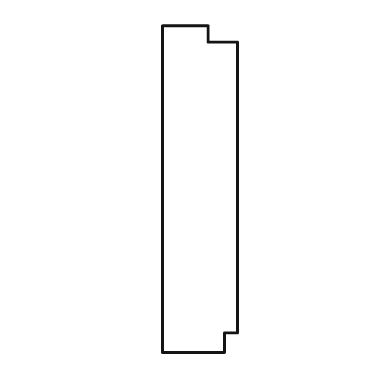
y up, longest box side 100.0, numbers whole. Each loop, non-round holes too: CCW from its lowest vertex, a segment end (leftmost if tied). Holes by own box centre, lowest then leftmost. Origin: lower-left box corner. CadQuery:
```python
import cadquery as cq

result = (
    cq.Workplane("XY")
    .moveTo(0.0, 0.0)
    .lineTo(19.0, 0.0)
    .lineTo(19.0, 6.0)
    .lineTo(23.0, 6.0)
    .lineTo(23.0, 95.0)
    .lineTo(14.0, 95.0)
    .lineTo(14.0, 100.0)
    .lineTo(0.0, 100.0)
    .close()
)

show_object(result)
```